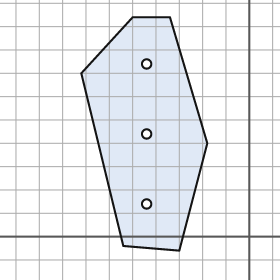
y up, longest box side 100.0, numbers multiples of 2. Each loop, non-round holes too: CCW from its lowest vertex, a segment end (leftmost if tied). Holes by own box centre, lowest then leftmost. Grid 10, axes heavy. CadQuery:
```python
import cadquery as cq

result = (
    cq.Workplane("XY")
    .moveTo(-30.0, -6.0)
    .lineTo(-18.0, 40.0)
    .lineTo(-34.0, 94.0)
    .lineTo(-50.0, 94.0)
    .lineTo(-72.0, 70.0)
    .lineTo(-54.0, -4.0)
    .close()
    .moveTo(-44.0, 14.0)
    .circle(2.0)
    .moveTo(-44.0, 44.0)
    .circle(2.0)
    .moveTo(-44.0, 74.0)
    .circle(2.0)
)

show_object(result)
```